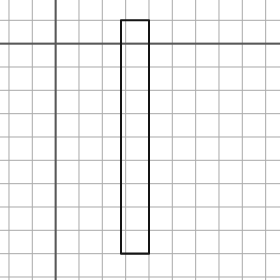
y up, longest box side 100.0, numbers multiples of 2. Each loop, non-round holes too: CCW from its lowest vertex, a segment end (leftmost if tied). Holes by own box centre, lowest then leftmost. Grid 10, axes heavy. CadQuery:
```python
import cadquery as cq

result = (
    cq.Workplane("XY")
    .moveTo(28.0, -90.0)
    .lineTo(40.0, -90.0)
    .lineTo(40.0, 10.0)
    .lineTo(28.0, 10.0)
    .close()
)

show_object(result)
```